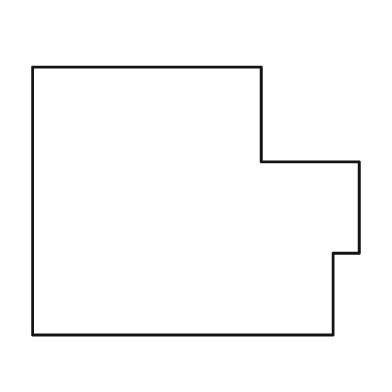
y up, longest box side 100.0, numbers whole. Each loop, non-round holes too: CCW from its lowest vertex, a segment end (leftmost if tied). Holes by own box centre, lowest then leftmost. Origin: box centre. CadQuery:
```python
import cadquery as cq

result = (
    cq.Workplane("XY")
    .moveTo(-50.0, -41.0)
    .lineTo(42.0, -41.0)
    .lineTo(42.0, -16.0)
    .lineTo(50.0, -16.0)
    .lineTo(50.0, 12.0)
    .lineTo(20.0, 12.0)
    .lineTo(20.0, 41.0)
    .lineTo(-50.0, 41.0)
    .close()
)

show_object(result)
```